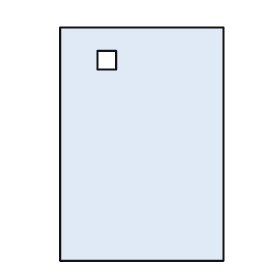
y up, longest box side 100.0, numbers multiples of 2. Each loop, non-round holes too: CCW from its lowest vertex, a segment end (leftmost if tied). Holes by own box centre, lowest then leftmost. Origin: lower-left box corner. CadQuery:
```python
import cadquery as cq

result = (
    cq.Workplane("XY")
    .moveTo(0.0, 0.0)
    .lineTo(70.0, 0.0)
    .lineTo(70.0, 100.0)
    .lineTo(0.0, 100.0)
    .close()
    .moveTo(16.0, 82.0)
    .lineTo(24.0, 82.0)
    .lineTo(24.0, 90.0)
    .lineTo(16.0, 90.0)
    .close()
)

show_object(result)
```